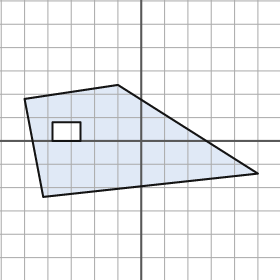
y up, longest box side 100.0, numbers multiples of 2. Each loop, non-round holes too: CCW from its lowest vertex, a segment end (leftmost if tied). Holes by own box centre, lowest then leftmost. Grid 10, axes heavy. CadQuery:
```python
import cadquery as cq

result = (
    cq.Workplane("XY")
    .moveTo(-42.0, -24.0)
    .lineTo(50.0, -14.0)
    .lineTo(-10.0, 24.0)
    .lineTo(-50.0, 18.0)
    .close()
    .moveTo(-38.0, 0.0)
    .lineTo(-26.0, 0.0)
    .lineTo(-26.0, 8.0)
    .lineTo(-38.0, 8.0)
    .close()
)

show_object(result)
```